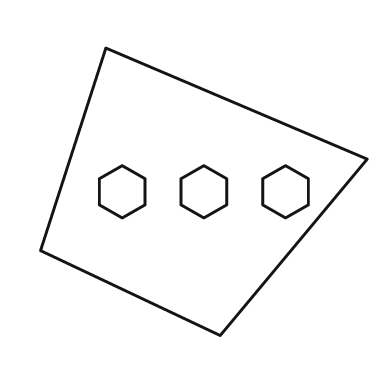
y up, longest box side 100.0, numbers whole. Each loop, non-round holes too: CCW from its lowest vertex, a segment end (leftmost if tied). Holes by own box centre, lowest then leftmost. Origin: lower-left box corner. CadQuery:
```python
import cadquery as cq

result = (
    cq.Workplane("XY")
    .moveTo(55.0, 0.0)
    .lineTo(100.0, 54.0)
    .lineTo(20.0, 88.0)
    .lineTo(0.0, 26.0)
    .close()
    .moveTo(25.0, 36.0)
    .lineTo(32.0, 40.0)
    .lineTo(32.0, 48.0)
    .lineTo(25.0, 52.0)
    .lineTo(18.0, 48.0)
    .lineTo(18.0, 40.0)
    .close()
    .moveTo(50.0, 36.0)
    .lineTo(57.0, 40.0)
    .lineTo(57.0, 48.0)
    .lineTo(50.0, 52.0)
    .lineTo(43.0, 48.0)
    .lineTo(43.0, 40.0)
    .close()
    .moveTo(75.0, 36.0)
    .lineTo(82.0, 40.0)
    .lineTo(82.0, 48.0)
    .lineTo(75.0, 52.0)
    .lineTo(68.0, 48.0)
    .lineTo(68.0, 40.0)
    .close()
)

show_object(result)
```